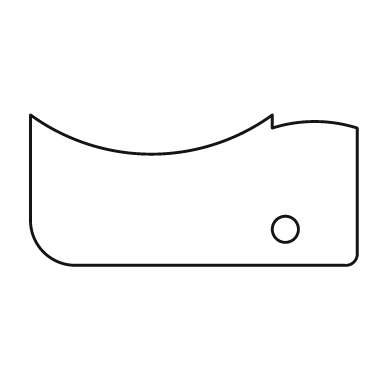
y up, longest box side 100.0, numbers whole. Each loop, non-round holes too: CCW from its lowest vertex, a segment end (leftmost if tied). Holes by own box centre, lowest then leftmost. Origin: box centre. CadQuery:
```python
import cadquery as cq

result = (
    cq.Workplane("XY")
    .moveTo(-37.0, -23.0)
    .lineTo(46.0, -23.0)
    .threePointArc((49.0, -22.0), (50.0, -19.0))
    .lineTo(50.0, 19.0)
    .threePointArc((37.0, 21.0), (24.0, 19.0))
    .lineTo(24.0, 23.0)
    .threePointArc((-13.0, 11.0), (-50.0, 23.0))
    .lineTo(-50.0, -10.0)
    .threePointArc((-46.0, -19.0), (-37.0, -23.0))
    .close()
    .moveTo(28.0, -12.0)
    .circle(4.0)
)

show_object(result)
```